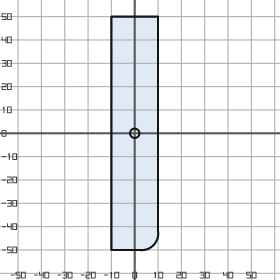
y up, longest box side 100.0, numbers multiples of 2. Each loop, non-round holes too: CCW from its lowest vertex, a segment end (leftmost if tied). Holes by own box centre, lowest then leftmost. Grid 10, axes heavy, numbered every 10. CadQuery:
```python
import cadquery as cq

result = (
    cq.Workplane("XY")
    .moveTo(-10.0, -50.0)
    .lineTo(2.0, -50.0)
    .threePointArc((8.0, -48.0), (10.0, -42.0))
    .lineTo(10.0, 50.0)
    .lineTo(-10.0, 50.0)
    .close()
    .moveTo(0.0, 0.0)
    .circle(2.0)
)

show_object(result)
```